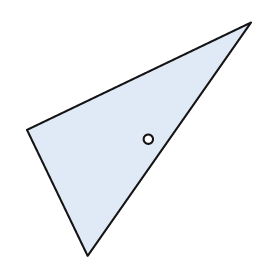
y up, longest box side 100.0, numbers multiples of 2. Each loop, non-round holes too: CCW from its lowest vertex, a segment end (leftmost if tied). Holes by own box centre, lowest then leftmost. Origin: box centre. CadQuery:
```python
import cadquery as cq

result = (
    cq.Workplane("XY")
    .moveTo(-22.0, -50.0)
    .lineTo(48.0, 50.0)
    .lineTo(-48.0, 4.0)
    .close()
    .moveTo(4.0, 0.0)
    .circle(2.0)
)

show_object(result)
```